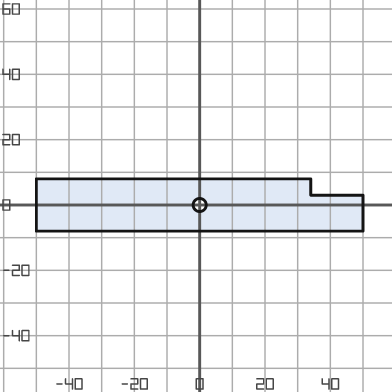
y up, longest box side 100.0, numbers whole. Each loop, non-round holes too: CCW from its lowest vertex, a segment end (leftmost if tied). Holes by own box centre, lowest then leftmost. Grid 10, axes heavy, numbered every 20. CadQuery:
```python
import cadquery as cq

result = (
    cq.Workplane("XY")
    .moveTo(-50.0, -8.0)
    .lineTo(50.0, -8.0)
    .lineTo(50.0, 3.0)
    .lineTo(34.0, 3.0)
    .lineTo(34.0, 8.0)
    .lineTo(-50.0, 8.0)
    .close()
    .moveTo(0.0, 0.0)
    .circle(2.0)
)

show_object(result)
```